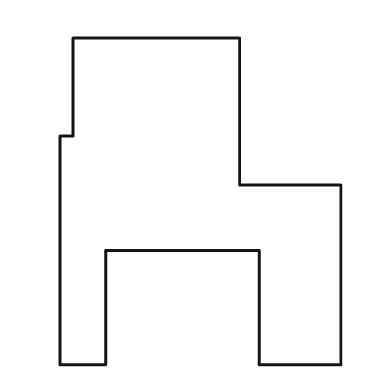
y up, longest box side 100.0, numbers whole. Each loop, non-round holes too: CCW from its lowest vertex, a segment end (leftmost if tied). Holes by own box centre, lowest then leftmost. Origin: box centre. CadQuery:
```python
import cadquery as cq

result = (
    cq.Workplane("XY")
    .moveTo(-43.0, -50.0)
    .lineTo(-29.0, -50.0)
    .lineTo(-29.0, -15.0)
    .lineTo(18.0, -15.0)
    .lineTo(18.0, -50.0)
    .lineTo(43.0, -50.0)
    .lineTo(43.0, 5.0)
    .lineTo(12.0, 5.0)
    .lineTo(12.0, 50.0)
    .lineTo(-39.0, 50.0)
    .lineTo(-39.0, 20.0)
    .lineTo(-43.0, 20.0)
    .close()
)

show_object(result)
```